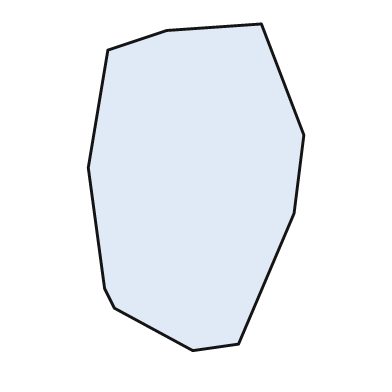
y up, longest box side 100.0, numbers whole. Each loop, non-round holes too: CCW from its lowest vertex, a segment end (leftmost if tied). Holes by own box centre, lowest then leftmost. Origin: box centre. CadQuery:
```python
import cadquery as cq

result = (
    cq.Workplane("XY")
    .moveTo(-1.0, -50.0)
    .lineTo(13.0, -48.0)
    .lineTo(30.0, -8.0)
    .lineTo(33.0, 16.0)
    .lineTo(20.0, 50.0)
    .lineTo(-9.0, 48.0)
    .lineTo(-27.0, 42.0)
    .lineTo(-33.0, 6.0)
    .lineTo(-28.0, -31.0)
    .lineTo(-25.0, -37.0)
    .close()
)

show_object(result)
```